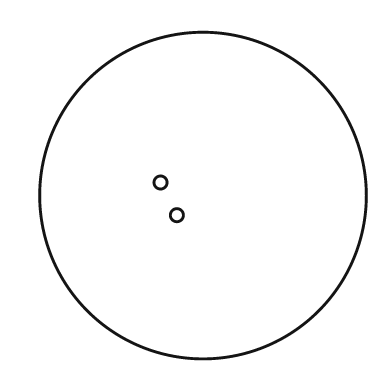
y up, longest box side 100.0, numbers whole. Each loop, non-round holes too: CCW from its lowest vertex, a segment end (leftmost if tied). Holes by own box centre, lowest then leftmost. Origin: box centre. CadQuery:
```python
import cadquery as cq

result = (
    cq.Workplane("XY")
    .moveTo(0.0, 0.0)
    .circle(50.0)
    .moveTo(-8.0, -6.0)
    .circle(2.0)
    .moveTo(-13.0, 4.0)
    .circle(2.0)
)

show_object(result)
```